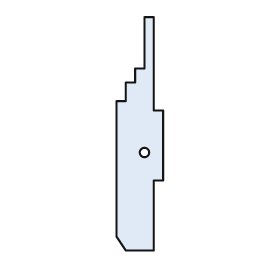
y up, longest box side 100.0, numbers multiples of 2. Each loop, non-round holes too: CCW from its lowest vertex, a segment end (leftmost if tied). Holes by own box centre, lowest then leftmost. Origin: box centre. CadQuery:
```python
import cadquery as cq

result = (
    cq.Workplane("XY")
    .moveTo(-6.0, -50.0)
    .lineTo(6.0, -50.0)
    .lineTo(6.0, -20.0)
    .lineTo(10.0, -20.0)
    .lineTo(10.0, 10.0)
    .lineTo(6.0, 10.0)
    .lineTo(6.0, 50.0)
    .lineTo(2.0, 50.0)
    .lineTo(2.0, 28.0)
    .lineTo(-2.0, 28.0)
    .lineTo(-2.0, 22.0)
    .lineTo(-6.0, 22.0)
    .lineTo(-6.0, 14.0)
    .lineTo(-10.0, 14.0)
    .lineTo(-10.0, -44.0)
    .close()
    .moveTo(2.0, -8.0)
    .circle(2.0)
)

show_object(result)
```